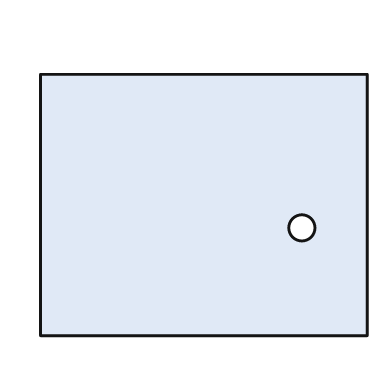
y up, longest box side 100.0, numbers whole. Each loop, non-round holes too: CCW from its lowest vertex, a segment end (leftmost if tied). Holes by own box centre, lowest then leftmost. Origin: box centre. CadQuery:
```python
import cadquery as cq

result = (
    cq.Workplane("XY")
    .moveTo(-50.0, -40.0)
    .lineTo(50.0, -40.0)
    .lineTo(50.0, 40.0)
    .lineTo(-50.0, 40.0)
    .close()
    .moveTo(30.0, -7.0)
    .circle(4.0)
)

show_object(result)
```